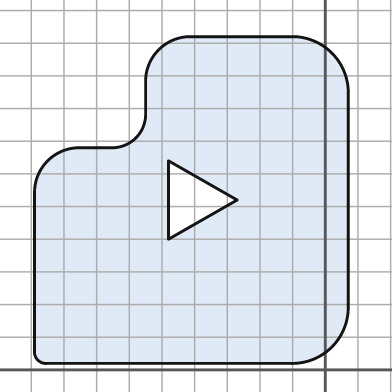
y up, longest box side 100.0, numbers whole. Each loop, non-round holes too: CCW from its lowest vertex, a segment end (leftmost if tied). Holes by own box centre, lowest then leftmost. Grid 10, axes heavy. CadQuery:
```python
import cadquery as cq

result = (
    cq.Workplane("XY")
    .moveTo(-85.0, 2.0)
    .lineTo(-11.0, 2.0)
    .threePointArc((2.0, 7.0), (7.0, 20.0))
    .lineTo(7.0, 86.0)
    .threePointArc((2.0, 97.0), (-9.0, 102.0))
    .lineTo(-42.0, 102.0)
    .threePointArc((-51.0, 98.0), (-55.0, 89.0))
    .lineTo(-55.0, 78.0)
    .threePointArc((-58.0, 71.0), (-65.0, 68.0))
    .lineTo(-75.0, 68.0)
    .threePointArc((-85.0, 64.0), (-89.0, 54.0))
    .lineTo(-89.0, 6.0)
    .threePointArc((-88.0, 3.0), (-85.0, 2.0))
    .close()
    .moveTo(-48.0, 40.0)
    .lineTo(-27.0, 52.0)
    .lineTo(-48.0, 64.0)
    .close()
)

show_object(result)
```